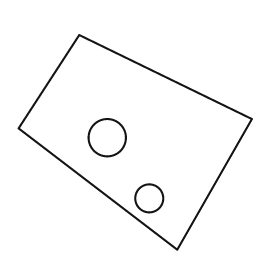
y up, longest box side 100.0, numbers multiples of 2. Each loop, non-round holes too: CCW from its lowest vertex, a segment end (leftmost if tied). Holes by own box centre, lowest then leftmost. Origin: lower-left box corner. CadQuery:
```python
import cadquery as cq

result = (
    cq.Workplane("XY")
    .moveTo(68.0, 0.0)
    .lineTo(100.0, 56.0)
    .lineTo(26.0, 92.0)
    .lineTo(0.0, 52.0)
    .close()
    .moveTo(56.0, 22.0)
    .circle(6.0)
    .moveTo(38.0, 48.0)
    .circle(8.0)
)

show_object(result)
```